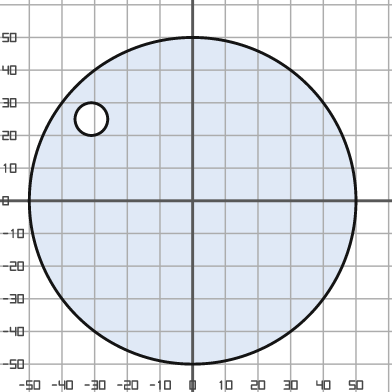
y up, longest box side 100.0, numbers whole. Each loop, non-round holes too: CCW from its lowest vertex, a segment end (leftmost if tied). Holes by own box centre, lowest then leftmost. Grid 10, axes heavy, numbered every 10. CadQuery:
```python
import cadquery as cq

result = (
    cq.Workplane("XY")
    .moveTo(0.0, 0.0)
    .circle(50.0)
    .moveTo(-31.0, 25.0)
    .circle(5.0)
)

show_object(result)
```